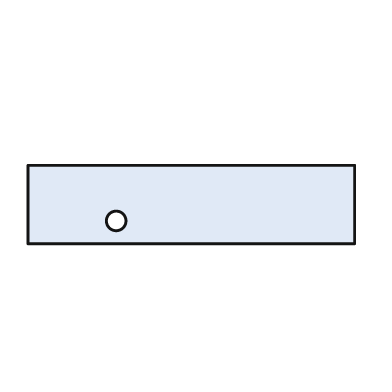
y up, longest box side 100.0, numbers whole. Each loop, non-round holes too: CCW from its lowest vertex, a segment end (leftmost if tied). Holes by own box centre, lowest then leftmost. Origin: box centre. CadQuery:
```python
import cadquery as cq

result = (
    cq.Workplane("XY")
    .moveTo(-50.0, -12.0)
    .lineTo(50.0, -12.0)
    .lineTo(50.0, 12.0)
    .lineTo(-50.0, 12.0)
    .close()
    .moveTo(-23.0, -5.0)
    .circle(3.0)
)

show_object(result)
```